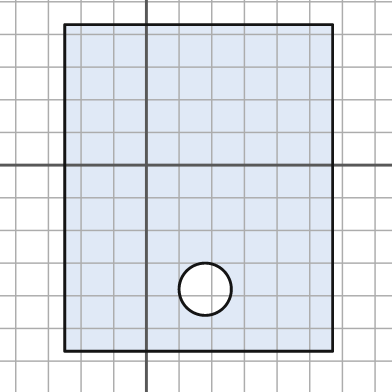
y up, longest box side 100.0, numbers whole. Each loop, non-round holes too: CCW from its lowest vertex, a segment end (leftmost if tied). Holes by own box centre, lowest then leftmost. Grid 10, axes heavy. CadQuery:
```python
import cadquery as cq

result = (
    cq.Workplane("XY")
    .moveTo(-25.0, -57.0)
    .lineTo(57.0, -57.0)
    .lineTo(57.0, 43.0)
    .lineTo(-25.0, 43.0)
    .close()
    .moveTo(18.0, -38.0)
    .circle(8.0)
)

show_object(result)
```